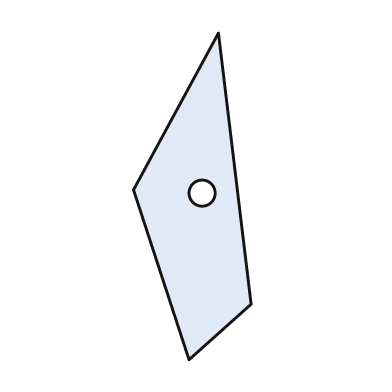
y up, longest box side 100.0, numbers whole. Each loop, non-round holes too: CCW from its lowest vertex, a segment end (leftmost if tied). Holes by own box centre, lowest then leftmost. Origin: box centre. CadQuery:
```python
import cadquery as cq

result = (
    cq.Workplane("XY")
    .moveTo(-1.0, -50.0)
    .lineTo(18.0, -33.0)
    .lineTo(8.0, 50.0)
    .lineTo(-18.0, 2.0)
    .close()
    .moveTo(3.0, 1.0)
    .circle(4.0)
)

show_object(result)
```